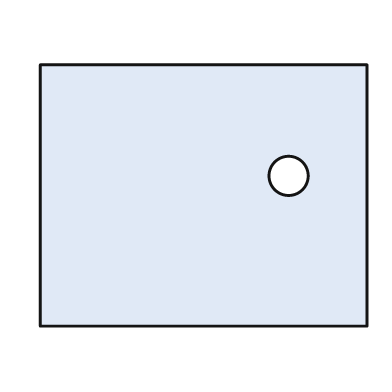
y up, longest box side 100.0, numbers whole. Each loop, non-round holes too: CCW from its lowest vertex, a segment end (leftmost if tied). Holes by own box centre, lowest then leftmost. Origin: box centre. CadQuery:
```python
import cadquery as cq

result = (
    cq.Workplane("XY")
    .moveTo(-50.0, -40.0)
    .lineTo(50.0, -40.0)
    .lineTo(50.0, 40.0)
    .lineTo(-50.0, 40.0)
    .close()
    .moveTo(26.0, 6.0)
    .circle(6.0)
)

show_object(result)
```